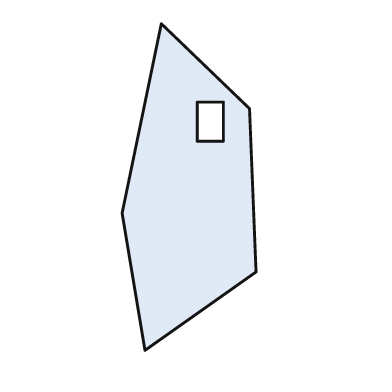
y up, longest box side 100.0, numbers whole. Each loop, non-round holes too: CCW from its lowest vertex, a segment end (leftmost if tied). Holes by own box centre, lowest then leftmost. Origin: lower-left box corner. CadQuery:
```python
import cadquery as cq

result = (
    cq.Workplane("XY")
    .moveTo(7.0, 0.0)
    .lineTo(41.0, 24.0)
    .lineTo(39.0, 74.0)
    .lineTo(12.0, 100.0)
    .lineTo(0.0, 42.0)
    .close()
    .moveTo(23.0, 64.0)
    .lineTo(31.0, 64.0)
    .lineTo(31.0, 76.0)
    .lineTo(23.0, 76.0)
    .close()
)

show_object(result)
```